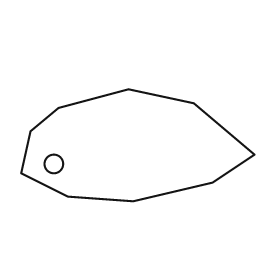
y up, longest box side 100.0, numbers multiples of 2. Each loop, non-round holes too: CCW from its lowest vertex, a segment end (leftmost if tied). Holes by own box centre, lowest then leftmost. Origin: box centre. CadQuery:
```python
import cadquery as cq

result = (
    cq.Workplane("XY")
    .moveTo(-2.0, -24.0)
    .lineTo(32.0, -16.0)
    .lineTo(50.0, -4.0)
    .lineTo(24.0, 18.0)
    .lineTo(-4.0, 24.0)
    .lineTo(-34.0, 16.0)
    .lineTo(-46.0, 6.0)
    .lineTo(-50.0, -12.0)
    .lineTo(-30.0, -22.0)
    .close()
    .moveTo(-36.0, -8.0)
    .circle(4.0)
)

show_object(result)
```